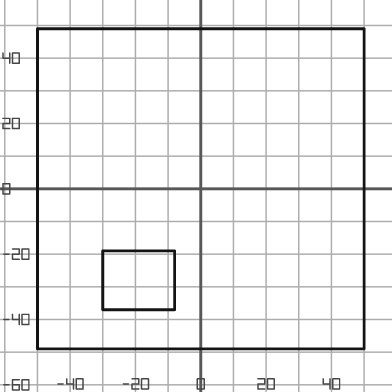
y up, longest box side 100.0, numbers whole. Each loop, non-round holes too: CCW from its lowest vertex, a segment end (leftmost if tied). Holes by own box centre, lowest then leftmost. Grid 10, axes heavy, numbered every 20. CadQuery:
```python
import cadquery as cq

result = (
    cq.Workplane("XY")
    .moveTo(-50.0, -49.0)
    .lineTo(50.0, -49.0)
    .lineTo(50.0, 49.0)
    .lineTo(-50.0, 49.0)
    .close()
    .moveTo(-30.0, -37.0)
    .lineTo(-8.0, -37.0)
    .lineTo(-8.0, -19.0)
    .lineTo(-30.0, -19.0)
    .close()
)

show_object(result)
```